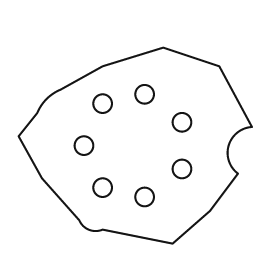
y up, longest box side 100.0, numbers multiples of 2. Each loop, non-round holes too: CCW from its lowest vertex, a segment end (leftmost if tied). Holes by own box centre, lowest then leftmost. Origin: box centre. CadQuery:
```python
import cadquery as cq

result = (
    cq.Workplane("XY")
    .moveTo(16.0, -42.0)
    .lineTo(32.0, -28.0)
    .lineTo(44.0, -12.0)
    .threePointArc((40.0, 0.0), (50.0, 8.0))
    .lineTo(36.0, 34.0)
    .lineTo(12.0, 42.0)
    .lineTo(-14.0, 34.0)
    .lineTo(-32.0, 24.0)
    .threePointArc((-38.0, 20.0), (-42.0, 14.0))
    .lineTo(-50.0, 4.0)
    .lineTo(-40.0, -14.0)
    .lineTo(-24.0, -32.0)
    .threePointArc((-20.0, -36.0), (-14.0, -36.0))
    .close()
    .moveTo(4.0, -22.0)
    .circle(4.0)
    .moveTo(-14.0, -18.0)
    .circle(4.0)
    .moveTo(20.0, -10.0)
    .circle(4.0)
    .moveTo(-22.0, 0.0)
    .circle(4.0)
    .moveTo(20.0, 10.0)
    .circle(4.0)
    .moveTo(-14.0, 18.0)
    .circle(4.0)
    .moveTo(4.0, 22.0)
    .circle(4.0)
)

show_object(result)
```